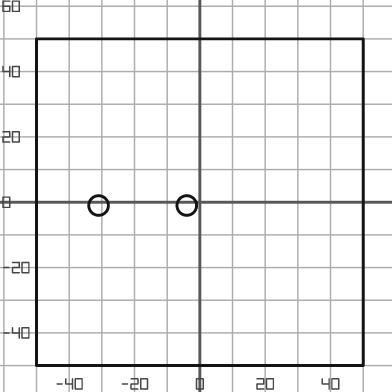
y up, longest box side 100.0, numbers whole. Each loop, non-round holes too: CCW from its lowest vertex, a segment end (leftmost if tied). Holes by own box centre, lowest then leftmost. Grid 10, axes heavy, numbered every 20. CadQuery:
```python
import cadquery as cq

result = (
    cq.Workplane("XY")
    .moveTo(-50.0, -50.0)
    .lineTo(50.0, -50.0)
    .lineTo(50.0, 50.0)
    .lineTo(-50.0, 50.0)
    .close()
    .moveTo(-31.0, -1.0)
    .circle(3.0)
    .moveTo(-4.0, -1.0)
    .circle(3.0)
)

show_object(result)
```